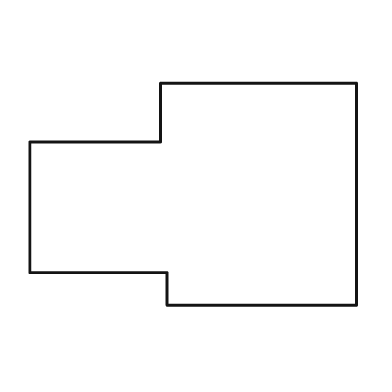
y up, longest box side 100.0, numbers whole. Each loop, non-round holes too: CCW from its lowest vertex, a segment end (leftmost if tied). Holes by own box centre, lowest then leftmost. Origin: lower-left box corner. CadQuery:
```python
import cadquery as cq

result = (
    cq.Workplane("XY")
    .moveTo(42.0, 0.0)
    .lineTo(100.0, 0.0)
    .lineTo(100.0, 68.0)
    .lineTo(40.0, 68.0)
    .lineTo(40.0, 50.0)
    .lineTo(0.0, 50.0)
    .lineTo(0.0, 10.0)
    .lineTo(42.0, 10.0)
    .close()
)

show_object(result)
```